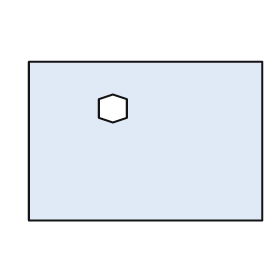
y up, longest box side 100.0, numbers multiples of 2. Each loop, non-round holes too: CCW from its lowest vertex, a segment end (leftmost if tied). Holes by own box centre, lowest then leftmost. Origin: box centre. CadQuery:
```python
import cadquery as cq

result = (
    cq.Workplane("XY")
    .moveTo(-50.0, -34.0)
    .lineTo(50.0, -34.0)
    .lineTo(50.0, 34.0)
    .lineTo(-50.0, 34.0)
    .close()
    .moveTo(-14.0, 8.0)
    .lineTo(-8.0, 10.0)
    .lineTo(-8.0, 18.0)
    .lineTo(-14.0, 20.0)
    .lineTo(-20.0, 18.0)
    .lineTo(-20.0, 10.0)
    .close()
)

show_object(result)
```